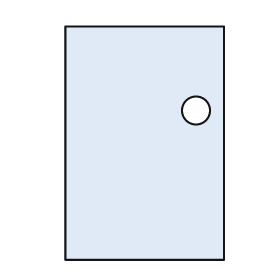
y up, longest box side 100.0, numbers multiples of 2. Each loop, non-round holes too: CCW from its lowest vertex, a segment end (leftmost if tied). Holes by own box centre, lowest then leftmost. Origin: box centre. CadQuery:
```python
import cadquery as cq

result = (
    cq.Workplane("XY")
    .moveTo(-34.0, -50.0)
    .lineTo(34.0, -50.0)
    .lineTo(34.0, 50.0)
    .lineTo(-34.0, 50.0)
    .close()
    .moveTo(22.0, 14.0)
    .circle(6.0)
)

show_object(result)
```